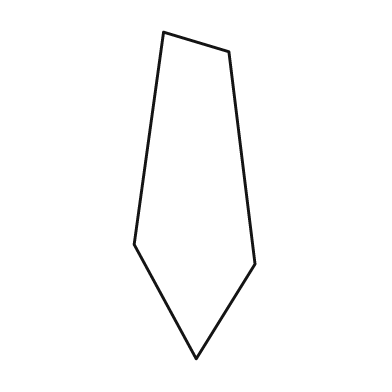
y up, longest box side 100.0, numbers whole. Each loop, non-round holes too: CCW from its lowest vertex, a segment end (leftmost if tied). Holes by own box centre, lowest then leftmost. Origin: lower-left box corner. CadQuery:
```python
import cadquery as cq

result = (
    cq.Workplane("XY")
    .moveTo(19.0, 0.0)
    .lineTo(37.0, 29.0)
    .lineTo(29.0, 94.0)
    .lineTo(9.0, 100.0)
    .lineTo(0.0, 35.0)
    .close()
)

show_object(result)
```